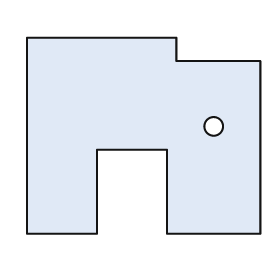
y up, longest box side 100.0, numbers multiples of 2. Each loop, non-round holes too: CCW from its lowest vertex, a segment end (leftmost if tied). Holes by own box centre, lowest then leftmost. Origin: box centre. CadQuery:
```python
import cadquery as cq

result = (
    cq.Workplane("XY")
    .moveTo(-50.0, -42.0)
    .lineTo(-20.0, -42.0)
    .lineTo(-20.0, -6.0)
    .lineTo(10.0, -6.0)
    .lineTo(10.0, -42.0)
    .lineTo(50.0, -42.0)
    .lineTo(50.0, 32.0)
    .lineTo(14.0, 32.0)
    .lineTo(14.0, 42.0)
    .lineTo(-50.0, 42.0)
    .close()
    .moveTo(30.0, 4.0)
    .circle(4.0)
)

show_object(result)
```